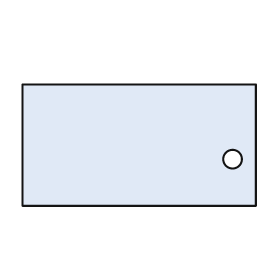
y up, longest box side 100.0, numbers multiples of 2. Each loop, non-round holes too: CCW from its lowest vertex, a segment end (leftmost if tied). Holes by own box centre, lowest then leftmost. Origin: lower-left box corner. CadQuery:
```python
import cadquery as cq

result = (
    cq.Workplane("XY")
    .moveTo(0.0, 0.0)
    .lineTo(100.0, 0.0)
    .lineTo(100.0, 52.0)
    .lineTo(0.0, 52.0)
    .close()
    .moveTo(90.0, 20.0)
    .circle(4.0)
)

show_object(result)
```